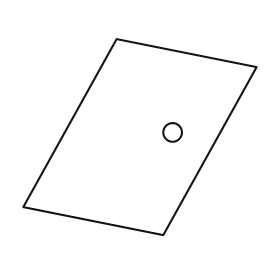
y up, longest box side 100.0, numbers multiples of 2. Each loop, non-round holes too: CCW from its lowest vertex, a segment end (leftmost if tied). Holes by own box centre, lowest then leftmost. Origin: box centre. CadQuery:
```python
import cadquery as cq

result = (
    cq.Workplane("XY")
    .moveTo(10.0, -42.0)
    .lineTo(50.0, 30.0)
    .lineTo(-10.0, 42.0)
    .lineTo(-50.0, -30.0)
    .close()
    .moveTo(14.0, 2.0)
    .circle(4.0)
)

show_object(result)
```